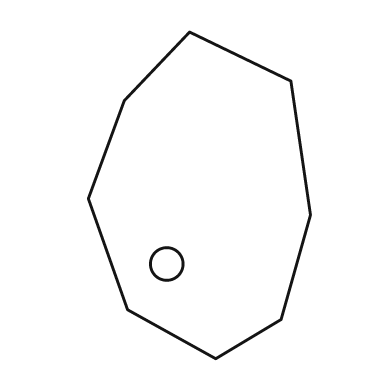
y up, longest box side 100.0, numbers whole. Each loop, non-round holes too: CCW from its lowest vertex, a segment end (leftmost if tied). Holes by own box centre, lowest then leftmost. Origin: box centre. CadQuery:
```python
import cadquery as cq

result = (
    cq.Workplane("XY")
    .moveTo(5.0, -50.0)
    .lineTo(25.0, -38.0)
    .lineTo(34.0, -6.0)
    .lineTo(28.0, 35.0)
    .lineTo(-3.0, 50.0)
    .lineTo(-23.0, 29.0)
    .lineTo(-34.0, -1.0)
    .lineTo(-22.0, -35.0)
    .close()
    .moveTo(-10.0, -21.0)
    .circle(5.0)
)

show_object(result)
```